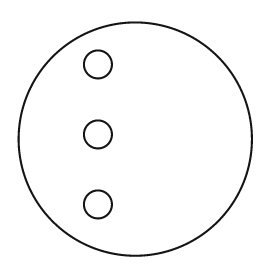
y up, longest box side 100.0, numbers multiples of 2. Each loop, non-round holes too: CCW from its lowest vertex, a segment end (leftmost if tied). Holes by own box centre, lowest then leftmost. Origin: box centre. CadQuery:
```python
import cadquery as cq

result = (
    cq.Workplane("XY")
    .moveTo(0.0, 0.0)
    .circle(50.0)
    .moveTo(-16.0, -28.0)
    .circle(6.0)
    .moveTo(-16.0, 2.0)
    .circle(6.0)
    .moveTo(-16.0, 32.0)
    .circle(6.0)
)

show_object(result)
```